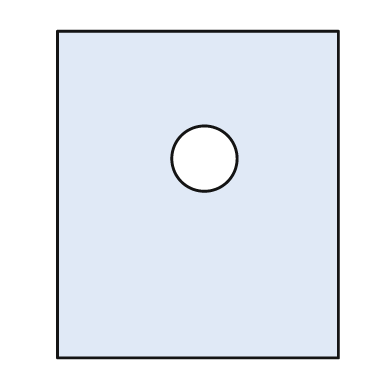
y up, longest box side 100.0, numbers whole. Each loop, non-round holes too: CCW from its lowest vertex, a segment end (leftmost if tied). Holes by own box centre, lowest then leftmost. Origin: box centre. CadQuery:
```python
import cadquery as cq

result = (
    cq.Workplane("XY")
    .moveTo(-43.0, -50.0)
    .lineTo(43.0, -50.0)
    .lineTo(43.0, 50.0)
    .lineTo(-43.0, 50.0)
    .close()
    .moveTo(2.0, 11.0)
    .circle(10.0)
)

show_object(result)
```